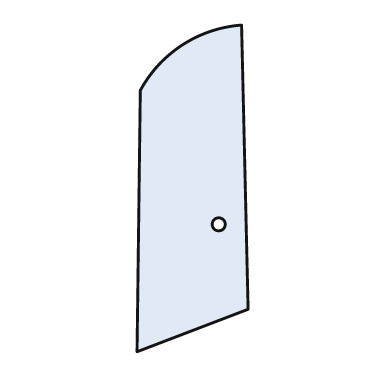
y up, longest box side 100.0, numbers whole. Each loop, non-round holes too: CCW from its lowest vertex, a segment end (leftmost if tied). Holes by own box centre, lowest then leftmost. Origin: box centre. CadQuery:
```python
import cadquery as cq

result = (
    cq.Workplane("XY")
    .moveTo(-17.0, -50.0)
    .lineTo(17.0, -37.0)
    .lineTo(15.0, 50.0)
    .threePointArc((-3.0, 44.0), (-16.0, 30.0))
    .close()
    .moveTo(8.0, -11.0)
    .circle(2.0)
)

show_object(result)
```